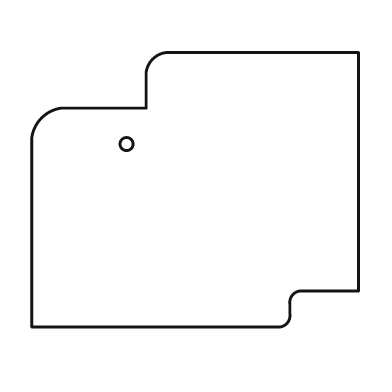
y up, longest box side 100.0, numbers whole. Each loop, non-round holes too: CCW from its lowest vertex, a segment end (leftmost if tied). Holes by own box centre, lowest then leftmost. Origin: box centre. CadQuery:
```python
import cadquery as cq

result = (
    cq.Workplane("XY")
    .moveTo(-50.0, -42.0)
    .lineTo(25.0, -42.0)
    .threePointArc((28.0, -41.0), (29.0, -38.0))
    .lineTo(29.0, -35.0)
    .threePointArc((30.0, -32.0), (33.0, -31.0))
    .lineTo(50.0, -31.0)
    .lineTo(50.0, 42.0)
    .lineTo(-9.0, 42.0)
    .threePointArc((-13.0, 40.0), (-15.0, 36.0))
    .lineTo(-15.0, 25.0)
    .lineTo(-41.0, 25.0)
    .threePointArc((-47.0, 22.0), (-50.0, 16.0))
    .close()
    .moveTo(-21.0, 14.0)
    .circle(2.0)
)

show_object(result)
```